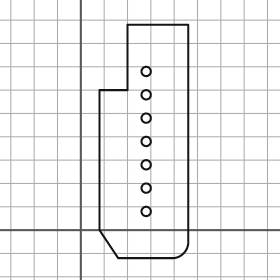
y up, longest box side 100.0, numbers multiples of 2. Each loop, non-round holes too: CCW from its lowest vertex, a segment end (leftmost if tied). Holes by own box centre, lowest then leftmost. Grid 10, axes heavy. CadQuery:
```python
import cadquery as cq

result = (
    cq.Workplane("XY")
    .moveTo(16.0, -12.0)
    .lineTo(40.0, -12.0)
    .threePointArc((44.0, -10.0), (46.0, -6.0))
    .lineTo(46.0, 88.0)
    .lineTo(20.0, 88.0)
    .lineTo(20.0, 60.0)
    .lineTo(8.0, 60.0)
    .lineTo(8.0, 0.0)
    .close()
    .moveTo(28.0, 8.0)
    .circle(2.0)
    .moveTo(28.0, 18.0)
    .circle(2.0)
    .moveTo(28.0, 28.0)
    .circle(2.0)
    .moveTo(28.0, 38.0)
    .circle(2.0)
    .moveTo(28.0, 48.0)
    .circle(2.0)
    .moveTo(28.0, 58.0)
    .circle(2.0)
    .moveTo(28.0, 68.0)
    .circle(2.0)
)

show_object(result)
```